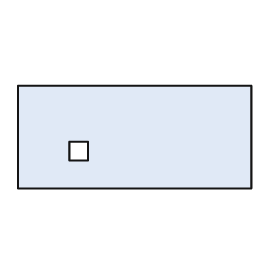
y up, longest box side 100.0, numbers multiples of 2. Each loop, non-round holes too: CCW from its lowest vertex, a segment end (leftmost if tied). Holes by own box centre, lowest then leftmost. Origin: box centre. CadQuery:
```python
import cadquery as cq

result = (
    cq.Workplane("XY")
    .moveTo(-50.0, -22.0)
    .lineTo(50.0, -22.0)
    .lineTo(50.0, 22.0)
    .lineTo(-50.0, 22.0)
    .close()
    .moveTo(-28.0, -10.0)
    .lineTo(-20.0, -10.0)
    .lineTo(-20.0, -2.0)
    .lineTo(-28.0, -2.0)
    .close()
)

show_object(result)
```